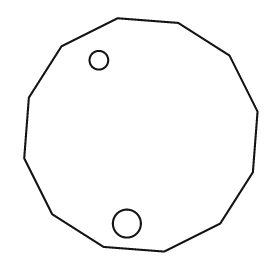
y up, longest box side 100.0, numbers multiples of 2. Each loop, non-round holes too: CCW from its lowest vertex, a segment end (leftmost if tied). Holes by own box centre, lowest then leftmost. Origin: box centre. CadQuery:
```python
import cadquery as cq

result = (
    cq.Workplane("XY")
    .moveTo(10.0, -50.0)
    .lineTo(34.0, -38.0)
    .lineTo(48.0, -16.0)
    .lineTo(50.0, 10.0)
    .lineTo(38.0, 34.0)
    .lineTo(16.0, 48.0)
    .lineTo(-10.0, 50.0)
    .lineTo(-34.0, 38.0)
    .lineTo(-48.0, 16.0)
    .lineTo(-50.0, -10.0)
    .lineTo(-38.0, -34.0)
    .lineTo(-16.0, -48.0)
    .close()
    .moveTo(-6.0, -38.0)
    .circle(6.0)
    .moveTo(-18.0, 32.0)
    .circle(4.0)
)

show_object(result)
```